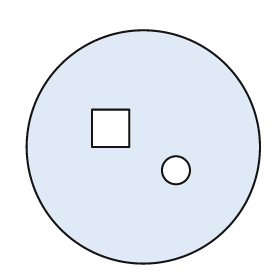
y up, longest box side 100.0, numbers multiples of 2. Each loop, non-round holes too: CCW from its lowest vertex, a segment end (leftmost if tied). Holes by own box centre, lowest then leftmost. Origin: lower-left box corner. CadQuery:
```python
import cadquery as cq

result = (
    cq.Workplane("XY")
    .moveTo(50.0, 50.0)
    .circle(50.0)
    .moveTo(64.0, 40.0)
    .circle(6.0)
    .moveTo(28.0, 50.0)
    .lineTo(44.0, 50.0)
    .lineTo(44.0, 66.0)
    .lineTo(28.0, 66.0)
    .close()
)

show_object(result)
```